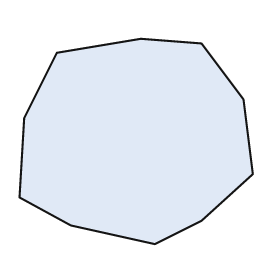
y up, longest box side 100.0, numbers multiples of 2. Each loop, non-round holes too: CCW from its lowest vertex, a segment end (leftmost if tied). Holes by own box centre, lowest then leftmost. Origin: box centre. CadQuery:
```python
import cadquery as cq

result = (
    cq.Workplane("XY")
    .moveTo(8.0, -44.0)
    .lineTo(28.0, -34.0)
    .lineTo(50.0, -14.0)
    .lineTo(46.0, 18.0)
    .lineTo(28.0, 42.0)
    .lineTo(2.0, 44.0)
    .lineTo(-34.0, 38.0)
    .lineTo(-48.0, 10.0)
    .lineTo(-50.0, -24.0)
    .lineTo(-28.0, -36.0)
    .close()
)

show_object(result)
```